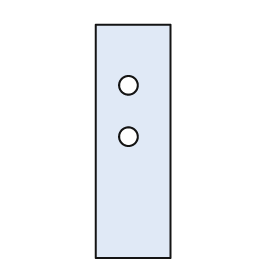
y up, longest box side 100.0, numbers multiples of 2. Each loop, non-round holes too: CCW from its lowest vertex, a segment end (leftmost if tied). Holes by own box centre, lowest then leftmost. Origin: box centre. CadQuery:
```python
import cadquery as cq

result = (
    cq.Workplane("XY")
    .moveTo(-16.0, -50.0)
    .lineTo(16.0, -50.0)
    .lineTo(16.0, 50.0)
    .lineTo(-16.0, 50.0)
    .close()
    .moveTo(-2.0, 2.0)
    .circle(4.0)
    .moveTo(-2.0, 24.0)
    .circle(4.0)
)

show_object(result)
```